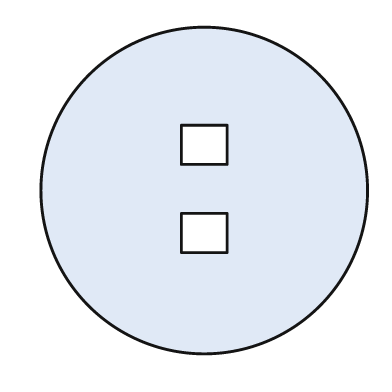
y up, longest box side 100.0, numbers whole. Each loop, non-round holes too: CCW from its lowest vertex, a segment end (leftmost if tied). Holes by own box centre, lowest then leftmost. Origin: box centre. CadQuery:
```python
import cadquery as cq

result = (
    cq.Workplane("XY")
    .moveTo(0.0, 0.0)
    .circle(50.0)
    .moveTo(-7.0, -19.0)
    .lineTo(7.0, -19.0)
    .lineTo(7.0, -7.0)
    .lineTo(-7.0, -7.0)
    .close()
    .moveTo(-7.0, 8.0)
    .lineTo(7.0, 8.0)
    .lineTo(7.0, 20.0)
    .lineTo(-7.0, 20.0)
    .close()
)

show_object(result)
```